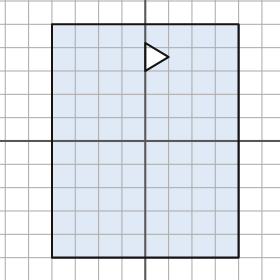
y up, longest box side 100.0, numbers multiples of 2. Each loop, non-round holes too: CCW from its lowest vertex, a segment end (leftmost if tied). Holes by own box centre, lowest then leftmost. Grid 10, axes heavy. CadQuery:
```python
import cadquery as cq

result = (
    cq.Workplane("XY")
    .moveTo(-40.0, -50.0)
    .lineTo(40.0, -50.0)
    .lineTo(40.0, 50.0)
    .lineTo(-40.0, 50.0)
    .close()
    .moveTo(0.0, 30.0)
    .lineTo(10.0, 36.0)
    .lineTo(0.0, 42.0)
    .close()
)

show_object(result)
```